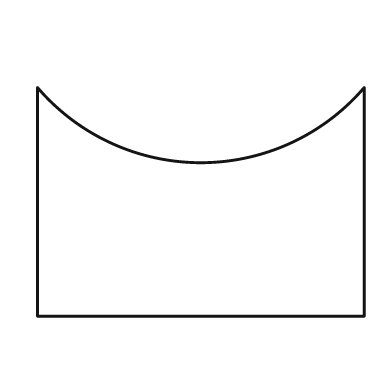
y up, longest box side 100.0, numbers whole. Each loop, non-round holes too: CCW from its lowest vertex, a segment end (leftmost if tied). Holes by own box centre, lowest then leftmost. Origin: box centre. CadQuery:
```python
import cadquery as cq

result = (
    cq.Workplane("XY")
    .moveTo(-50.0, -35.0)
    .lineTo(50.0, -35.0)
    .lineTo(50.0, 35.0)
    .threePointArc((0.0, 12.0), (-50.0, 35.0))
    .close()
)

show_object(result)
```